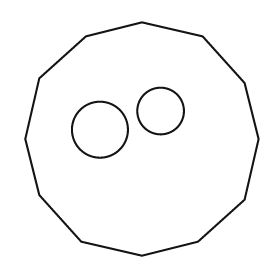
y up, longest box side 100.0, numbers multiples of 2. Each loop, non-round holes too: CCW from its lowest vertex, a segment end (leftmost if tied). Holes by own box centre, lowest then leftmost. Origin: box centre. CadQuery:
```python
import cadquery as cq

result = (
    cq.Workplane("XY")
    .moveTo(0.0, -50.0)
    .lineTo(24.0, -44.0)
    .lineTo(44.0, -26.0)
    .lineTo(50.0, 0.0)
    .lineTo(44.0, 24.0)
    .lineTo(26.0, 44.0)
    .lineTo(0.0, 50.0)
    .lineTo(-24.0, 44.0)
    .lineTo(-44.0, 26.0)
    .lineTo(-50.0, 0.0)
    .lineTo(-44.0, -24.0)
    .lineTo(-26.0, -44.0)
    .close()
    .moveTo(-18.0, 4.0)
    .circle(12.0)
    .moveTo(8.0, 12.0)
    .circle(10.0)
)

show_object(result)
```